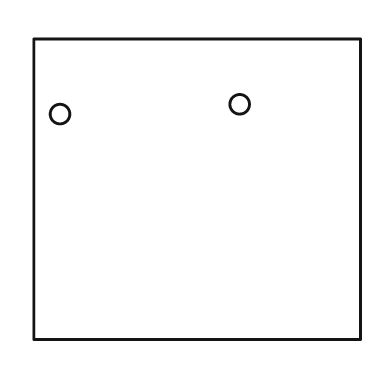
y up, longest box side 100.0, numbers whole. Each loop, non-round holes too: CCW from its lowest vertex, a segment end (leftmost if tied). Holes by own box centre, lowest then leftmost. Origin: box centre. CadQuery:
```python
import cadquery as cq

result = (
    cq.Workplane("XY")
    .moveTo(-50.0, -46.0)
    .lineTo(50.0, -46.0)
    .lineTo(50.0, 46.0)
    .lineTo(-50.0, 46.0)
    .close()
    .moveTo(-42.0, 23.0)
    .circle(3.0)
    .moveTo(13.0, 26.0)
    .circle(3.0)
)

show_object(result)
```